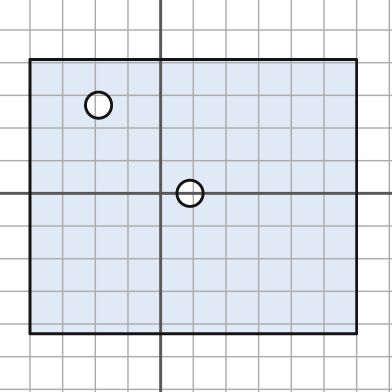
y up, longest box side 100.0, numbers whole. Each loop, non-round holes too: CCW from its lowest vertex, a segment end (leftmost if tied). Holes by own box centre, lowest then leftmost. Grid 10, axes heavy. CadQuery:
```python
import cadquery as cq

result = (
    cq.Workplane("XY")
    .moveTo(-40.0, -43.0)
    .lineTo(60.0, -43.0)
    .lineTo(60.0, 41.0)
    .lineTo(-40.0, 41.0)
    .close()
    .moveTo(9.0, 0.0)
    .circle(4.0)
    .moveTo(-19.0, 27.0)
    .circle(4.0)
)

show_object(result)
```